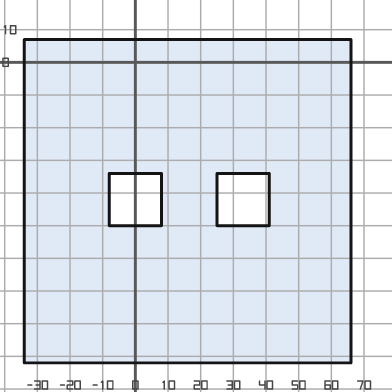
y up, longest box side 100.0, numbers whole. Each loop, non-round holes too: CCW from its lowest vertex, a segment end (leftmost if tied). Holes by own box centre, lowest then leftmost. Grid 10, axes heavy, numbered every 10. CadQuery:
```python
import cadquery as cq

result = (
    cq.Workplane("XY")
    .moveTo(-34.0, -92.0)
    .lineTo(66.0, -92.0)
    .lineTo(66.0, 7.0)
    .lineTo(-34.0, 7.0)
    .close()
    .moveTo(-8.0, -50.0)
    .lineTo(8.0, -50.0)
    .lineTo(8.0, -34.0)
    .lineTo(-8.0, -34.0)
    .close()
    .moveTo(25.0, -50.0)
    .lineTo(41.0, -50.0)
    .lineTo(41.0, -34.0)
    .lineTo(25.0, -34.0)
    .close()
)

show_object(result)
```